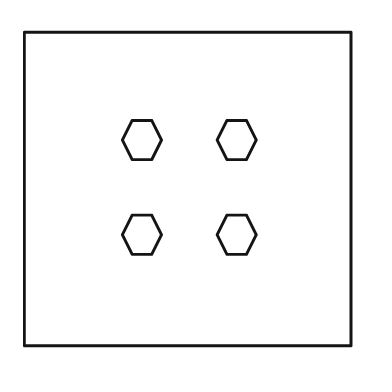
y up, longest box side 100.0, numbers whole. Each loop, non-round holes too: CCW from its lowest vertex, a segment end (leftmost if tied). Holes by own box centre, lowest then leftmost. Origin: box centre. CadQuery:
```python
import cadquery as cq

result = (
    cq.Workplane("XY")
    .moveTo(-50.0, -48.0)
    .lineTo(50.0, -48.0)
    .lineTo(50.0, 48.0)
    .lineTo(-50.0, 48.0)
    .close()
    .moveTo(-17.0, -20.0)
    .lineTo(-11.0, -20.0)
    .lineTo(-8.0, -14.0)
    .lineTo(-11.0, -8.0)
    .lineTo(-17.0, -8.0)
    .lineTo(-20.0, -14.0)
    .close()
    .moveTo(12.0, -20.0)
    .lineTo(18.0, -20.0)
    .lineTo(21.0, -14.0)
    .lineTo(18.0, -8.0)
    .lineTo(12.0, -8.0)
    .lineTo(9.0, -14.0)
    .close()
    .moveTo(-17.0, 9.0)
    .lineTo(-11.0, 9.0)
    .lineTo(-8.0, 15.0)
    .lineTo(-11.0, 21.0)
    .lineTo(-17.0, 21.0)
    .lineTo(-20.0, 15.0)
    .close()
    .moveTo(12.0, 9.0)
    .lineTo(18.0, 9.0)
    .lineTo(21.0, 15.0)
    .lineTo(18.0, 21.0)
    .lineTo(12.0, 21.0)
    .lineTo(9.0, 15.0)
    .close()
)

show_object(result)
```